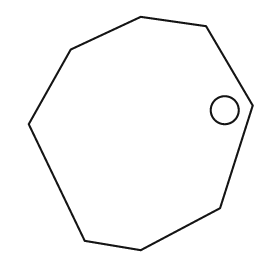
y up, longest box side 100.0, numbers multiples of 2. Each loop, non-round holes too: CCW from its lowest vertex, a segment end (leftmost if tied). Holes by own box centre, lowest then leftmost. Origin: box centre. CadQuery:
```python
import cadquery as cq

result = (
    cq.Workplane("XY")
    .moveTo(0.0, -50.0)
    .lineTo(34.0, -32.0)
    .lineTo(48.0, 12.0)
    .lineTo(28.0, 46.0)
    .lineTo(0.0, 50.0)
    .lineTo(-30.0, 36.0)
    .lineTo(-48.0, 4.0)
    .lineTo(-24.0, -46.0)
    .close()
    .moveTo(36.0, 10.0)
    .circle(6.0)
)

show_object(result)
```